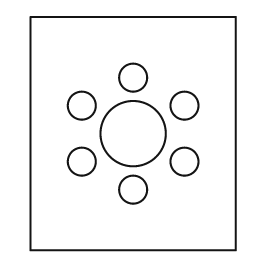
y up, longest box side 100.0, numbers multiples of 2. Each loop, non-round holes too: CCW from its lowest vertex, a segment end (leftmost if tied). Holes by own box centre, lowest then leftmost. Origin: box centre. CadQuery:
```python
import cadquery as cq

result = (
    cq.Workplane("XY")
    .moveTo(-44.0, -50.0)
    .lineTo(44.0, -50.0)
    .lineTo(44.0, 50.0)
    .lineTo(-44.0, 50.0)
    .close()
    .moveTo(0.0, -24.0)
    .circle(6.0)
    .moveTo(-22.0, -12.0)
    .circle(6.0)
    .moveTo(22.0, -12.0)
    .circle(6.0)
    .moveTo(0.0, 0.0)
    .circle(14.0)
    .moveTo(-22.0, 12.0)
    .circle(6.0)
    .moveTo(22.0, 12.0)
    .circle(6.0)
    .moveTo(0.0, 24.0)
    .circle(6.0)
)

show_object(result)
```